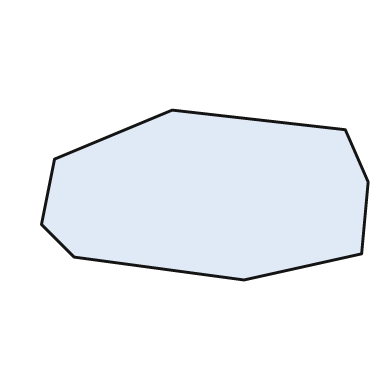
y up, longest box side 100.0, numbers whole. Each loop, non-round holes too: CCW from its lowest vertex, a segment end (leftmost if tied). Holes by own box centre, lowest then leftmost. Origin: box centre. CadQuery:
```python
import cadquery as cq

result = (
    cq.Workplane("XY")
    .moveTo(12.0, -26.0)
    .lineTo(48.0, -18.0)
    .lineTo(50.0, 4.0)
    .lineTo(43.0, 20.0)
    .lineTo(-10.0, 26.0)
    .lineTo(-46.0, 11.0)
    .lineTo(-50.0, -9.0)
    .lineTo(-40.0, -19.0)
    .close()
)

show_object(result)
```